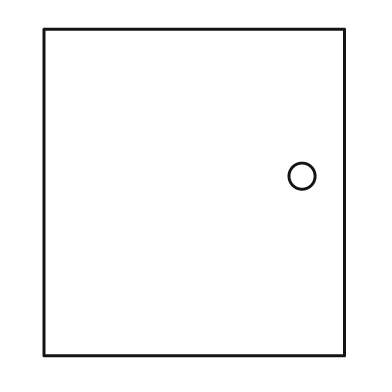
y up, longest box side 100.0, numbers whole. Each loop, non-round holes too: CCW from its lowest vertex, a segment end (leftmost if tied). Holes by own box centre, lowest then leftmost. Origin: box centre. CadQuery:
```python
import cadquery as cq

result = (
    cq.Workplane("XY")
    .moveTo(-46.0, -50.0)
    .lineTo(46.0, -50.0)
    .lineTo(46.0, 50.0)
    .lineTo(-46.0, 50.0)
    .close()
    .moveTo(33.0, 5.0)
    .circle(4.0)
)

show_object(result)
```